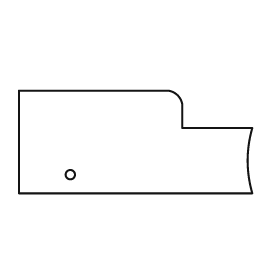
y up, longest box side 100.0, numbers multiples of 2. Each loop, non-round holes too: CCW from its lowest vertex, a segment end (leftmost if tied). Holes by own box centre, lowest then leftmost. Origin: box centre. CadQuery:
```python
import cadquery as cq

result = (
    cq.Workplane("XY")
    .moveTo(-50.0, -22.0)
    .lineTo(50.0, -22.0)
    .threePointArc((48.0, -8.0), (50.0, 6.0))
    .lineTo(20.0, 6.0)
    .lineTo(20.0, 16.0)
    .threePointArc((18.0, 20.0), (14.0, 22.0))
    .lineTo(-50.0, 22.0)
    .close()
    .moveTo(-28.0, -14.0)
    .circle(2.0)
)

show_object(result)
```